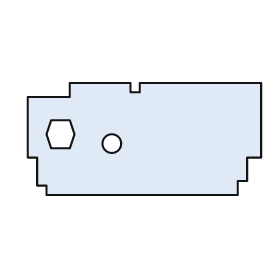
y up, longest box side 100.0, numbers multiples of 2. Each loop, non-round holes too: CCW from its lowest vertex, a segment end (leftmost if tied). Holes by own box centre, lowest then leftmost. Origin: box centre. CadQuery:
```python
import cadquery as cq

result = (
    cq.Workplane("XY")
    .moveTo(-42.0, -24.0)
    .lineTo(40.0, -24.0)
    .lineTo(40.0, -18.0)
    .lineTo(44.0, -18.0)
    .lineTo(44.0, -8.0)
    .lineTo(50.0, -8.0)
    .lineTo(50.0, 24.0)
    .lineTo(-2.0, 24.0)
    .lineTo(-2.0, 20.0)
    .lineTo(-6.0, 20.0)
    .lineTo(-6.0, 24.0)
    .lineTo(-32.0, 24.0)
    .lineTo(-32.0, 18.0)
    .lineTo(-50.0, 18.0)
    .lineTo(-50.0, -8.0)
    .lineTo(-46.0, -8.0)
    .lineTo(-46.0, -20.0)
    .lineTo(-42.0, -20.0)
    .close()
    .moveTo(-14.0, -2.0)
    .circle(4.0)
    .moveTo(-40.0, -4.0)
    .lineTo(-32.0, -4.0)
    .lineTo(-30.0, 2.0)
    .lineTo(-32.0, 8.0)
    .lineTo(-40.0, 8.0)
    .lineTo(-42.0, 2.0)
    .close()
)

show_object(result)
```